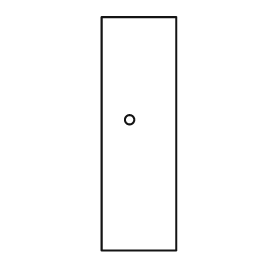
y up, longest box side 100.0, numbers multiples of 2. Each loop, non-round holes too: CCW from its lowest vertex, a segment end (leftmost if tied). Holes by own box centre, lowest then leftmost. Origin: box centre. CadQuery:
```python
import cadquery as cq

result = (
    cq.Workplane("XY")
    .moveTo(-16.0, -50.0)
    .lineTo(16.0, -50.0)
    .lineTo(16.0, 50.0)
    .lineTo(-16.0, 50.0)
    .close()
    .moveTo(-4.0, 6.0)
    .circle(2.0)
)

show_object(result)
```